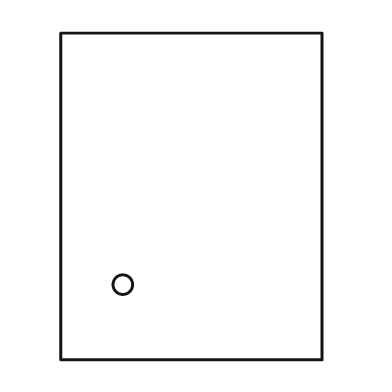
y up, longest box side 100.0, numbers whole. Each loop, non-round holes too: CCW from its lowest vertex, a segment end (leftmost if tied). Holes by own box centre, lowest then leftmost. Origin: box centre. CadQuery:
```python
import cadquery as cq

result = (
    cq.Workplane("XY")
    .moveTo(-40.0, -50.0)
    .lineTo(40.0, -50.0)
    .lineTo(40.0, 50.0)
    .lineTo(-40.0, 50.0)
    .close()
    .moveTo(-21.0, -27.0)
    .circle(3.0)
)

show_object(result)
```